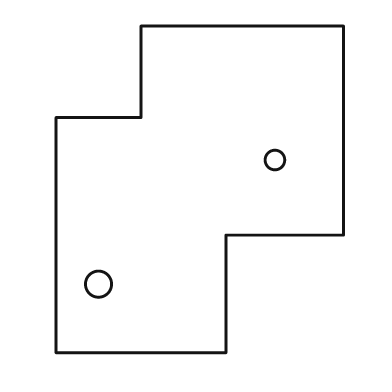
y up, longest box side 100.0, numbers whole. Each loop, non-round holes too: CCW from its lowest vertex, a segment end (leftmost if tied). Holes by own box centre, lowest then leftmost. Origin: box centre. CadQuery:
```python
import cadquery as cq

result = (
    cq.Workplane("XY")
    .moveTo(-44.0, -50.0)
    .lineTo(8.0, -50.0)
    .lineTo(8.0, -14.0)
    .lineTo(44.0, -14.0)
    .lineTo(44.0, 50.0)
    .lineTo(-18.0, 50.0)
    .lineTo(-18.0, 22.0)
    .lineTo(-44.0, 22.0)
    .close()
    .moveTo(-31.0, -29.0)
    .circle(4.0)
    .moveTo(23.0, 9.0)
    .circle(3.0)
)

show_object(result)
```